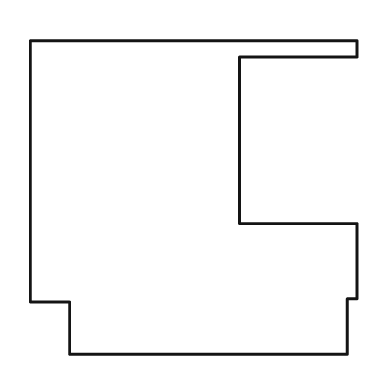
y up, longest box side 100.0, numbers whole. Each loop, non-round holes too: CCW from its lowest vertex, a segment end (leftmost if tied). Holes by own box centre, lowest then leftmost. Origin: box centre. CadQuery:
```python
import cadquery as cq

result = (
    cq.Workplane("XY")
    .moveTo(-38.0, -48.0)
    .lineTo(47.0, -48.0)
    .lineTo(47.0, -31.0)
    .lineTo(50.0, -31.0)
    .lineTo(50.0, -8.0)
    .lineTo(14.0, -8.0)
    .lineTo(14.0, 43.0)
    .lineTo(50.0, 43.0)
    .lineTo(50.0, 48.0)
    .lineTo(-50.0, 48.0)
    .lineTo(-50.0, -32.0)
    .lineTo(-38.0, -32.0)
    .close()
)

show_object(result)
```